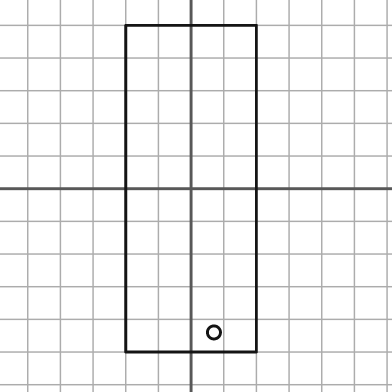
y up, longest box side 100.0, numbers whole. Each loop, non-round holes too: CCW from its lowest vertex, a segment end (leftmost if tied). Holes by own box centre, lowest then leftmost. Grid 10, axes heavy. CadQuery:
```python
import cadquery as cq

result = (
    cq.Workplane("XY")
    .moveTo(-20.0, -50.0)
    .lineTo(20.0, -50.0)
    .lineTo(20.0, 50.0)
    .lineTo(-20.0, 50.0)
    .close()
    .moveTo(7.0, -44.0)
    .circle(2.0)
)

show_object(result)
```